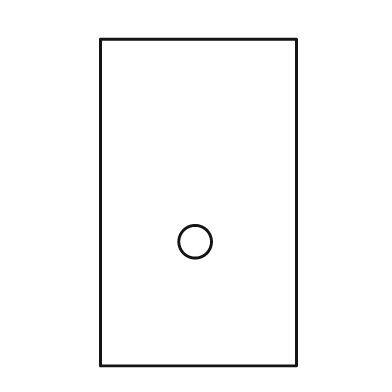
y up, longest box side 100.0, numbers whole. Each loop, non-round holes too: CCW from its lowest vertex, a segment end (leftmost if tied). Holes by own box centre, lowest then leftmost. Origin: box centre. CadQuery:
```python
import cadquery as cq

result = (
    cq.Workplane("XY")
    .moveTo(-30.0, -50.0)
    .lineTo(30.0, -50.0)
    .lineTo(30.0, 50.0)
    .lineTo(-30.0, 50.0)
    .close()
    .moveTo(-1.0, -12.0)
    .circle(5.0)
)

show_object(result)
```